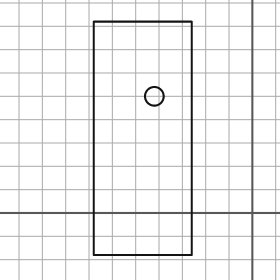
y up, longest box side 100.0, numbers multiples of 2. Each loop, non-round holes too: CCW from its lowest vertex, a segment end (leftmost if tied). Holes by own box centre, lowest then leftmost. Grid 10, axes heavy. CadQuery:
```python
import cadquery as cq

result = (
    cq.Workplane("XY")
    .moveTo(-68.0, -18.0)
    .lineTo(-26.0, -18.0)
    .lineTo(-26.0, 82.0)
    .lineTo(-68.0, 82.0)
    .close()
    .moveTo(-42.0, 50.0)
    .circle(4.0)
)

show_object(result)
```